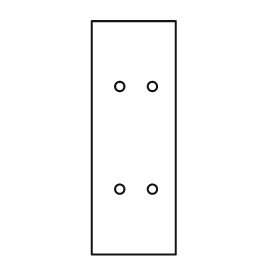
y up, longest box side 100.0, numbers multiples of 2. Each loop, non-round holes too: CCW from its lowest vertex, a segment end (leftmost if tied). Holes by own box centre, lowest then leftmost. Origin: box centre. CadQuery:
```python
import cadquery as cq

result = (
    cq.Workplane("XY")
    .moveTo(-18.0, -50.0)
    .lineTo(18.0, -50.0)
    .lineTo(18.0, 50.0)
    .lineTo(-18.0, 50.0)
    .close()
    .moveTo(-6.0, -22.0)
    .circle(2.0)
    .moveTo(8.0, -22.0)
    .circle(2.0)
    .moveTo(-6.0, 22.0)
    .circle(2.0)
    .moveTo(8.0, 22.0)
    .circle(2.0)
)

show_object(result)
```